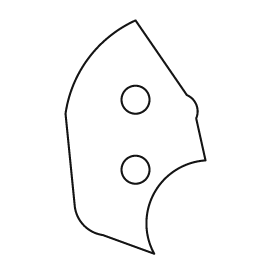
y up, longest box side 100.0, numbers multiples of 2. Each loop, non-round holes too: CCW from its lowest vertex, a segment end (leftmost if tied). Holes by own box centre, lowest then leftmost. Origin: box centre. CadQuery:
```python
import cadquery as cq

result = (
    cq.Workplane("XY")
    .moveTo(8.0, -50.0)
    .threePointArc((8.0, -24.0), (30.0, -10.0))
    .lineTo(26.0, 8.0)
    .threePointArc((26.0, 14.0), (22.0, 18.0))
    .lineTo(0.0, 50.0)
    .threePointArc((-20.0, 34.0), (-30.0, 10.0))
    .lineTo(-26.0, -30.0)
    .threePointArc((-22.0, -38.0), (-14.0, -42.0))
    .close()
    .moveTo(0.0, -14.0)
    .circle(6.0)
    .moveTo(0.0, 16.0)
    .circle(6.0)
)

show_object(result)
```